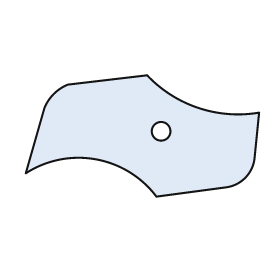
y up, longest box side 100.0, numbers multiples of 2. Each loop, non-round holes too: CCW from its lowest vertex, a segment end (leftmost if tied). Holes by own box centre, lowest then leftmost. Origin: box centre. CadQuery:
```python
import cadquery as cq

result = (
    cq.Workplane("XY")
    .moveTo(6.0, -26.0)
    .lineTo(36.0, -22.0)
    .threePointArc((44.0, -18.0), (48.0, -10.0))
    .lineTo(50.0, 10.0)
    .threePointArc((24.0, 12.0), (2.0, 26.0))
    .lineTo(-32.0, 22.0)
    .threePointArc((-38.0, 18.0), (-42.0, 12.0))
    .lineTo(-50.0, -16.0)
    .threePointArc((-20.0, -10.0), (6.0, -26.0))
    .close()
    .moveTo(8.0, 2.0)
    .circle(4.0)
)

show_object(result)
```